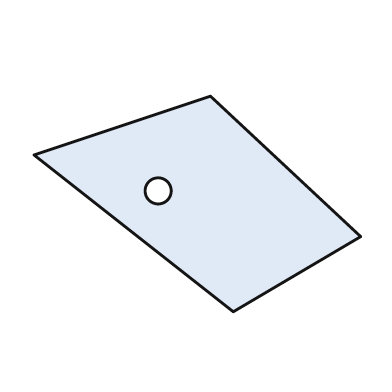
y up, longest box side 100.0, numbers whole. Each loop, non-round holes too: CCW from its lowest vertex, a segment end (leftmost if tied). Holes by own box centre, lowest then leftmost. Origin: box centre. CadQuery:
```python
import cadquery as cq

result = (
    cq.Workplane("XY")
    .moveTo(11.0, -33.0)
    .lineTo(50.0, -10.0)
    .lineTo(4.0, 33.0)
    .lineTo(-50.0, 15.0)
    .close()
    .moveTo(-12.0, 4.0)
    .circle(4.0)
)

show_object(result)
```